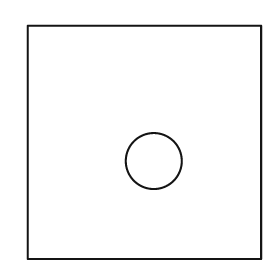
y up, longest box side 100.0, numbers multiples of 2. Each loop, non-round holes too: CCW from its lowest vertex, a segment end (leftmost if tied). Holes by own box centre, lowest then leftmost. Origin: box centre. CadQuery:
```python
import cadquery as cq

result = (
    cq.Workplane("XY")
    .moveTo(-50.0, -50.0)
    .lineTo(50.0, -50.0)
    .lineTo(50.0, 50.0)
    .lineTo(-50.0, 50.0)
    .close()
    .moveTo(4.0, -8.0)
    .circle(12.0)
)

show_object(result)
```